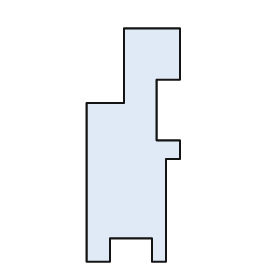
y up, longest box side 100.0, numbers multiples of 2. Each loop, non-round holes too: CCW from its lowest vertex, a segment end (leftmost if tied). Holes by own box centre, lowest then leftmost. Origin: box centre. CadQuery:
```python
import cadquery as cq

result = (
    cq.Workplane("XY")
    .moveTo(-20.0, -50.0)
    .lineTo(-10.0, -50.0)
    .lineTo(-10.0, -40.0)
    .lineTo(8.0, -40.0)
    .lineTo(8.0, -50.0)
    .lineTo(14.0, -50.0)
    .lineTo(14.0, -6.0)
    .lineTo(20.0, -6.0)
    .lineTo(20.0, 2.0)
    .lineTo(10.0, 2.0)
    .lineTo(10.0, 28.0)
    .lineTo(20.0, 28.0)
    .lineTo(20.0, 50.0)
    .lineTo(-4.0, 50.0)
    .lineTo(-4.0, 18.0)
    .lineTo(-20.0, 18.0)
    .close()
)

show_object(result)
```